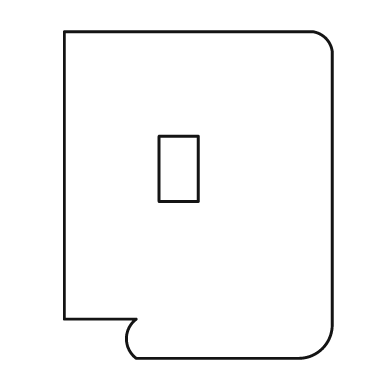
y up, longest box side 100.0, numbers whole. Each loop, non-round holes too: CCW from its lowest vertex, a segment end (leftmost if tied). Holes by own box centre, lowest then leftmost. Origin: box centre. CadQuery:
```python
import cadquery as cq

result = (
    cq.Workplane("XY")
    .moveTo(-19.0, -50.0)
    .lineTo(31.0, -50.0)
    .threePointArc((38.0, -47.0), (41.0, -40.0))
    .lineTo(41.0, 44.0)
    .threePointArc((39.0, 48.0), (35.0, 50.0))
    .lineTo(-41.0, 50.0)
    .lineTo(-41.0, -38.0)
    .lineTo(-19.0, -38.0)
    .threePointArc((-22.0, -44.0), (-19.0, -50.0))
    .close()
    .moveTo(-12.0, -2.0)
    .lineTo(0.0, -2.0)
    .lineTo(0.0, 18.0)
    .lineTo(-12.0, 18.0)
    .close()
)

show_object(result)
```